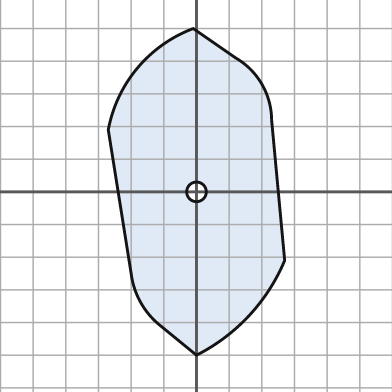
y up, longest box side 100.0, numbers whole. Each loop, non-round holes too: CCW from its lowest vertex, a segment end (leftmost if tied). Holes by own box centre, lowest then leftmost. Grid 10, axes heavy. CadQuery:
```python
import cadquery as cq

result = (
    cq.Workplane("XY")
    .moveTo(0.0, -50.0)
    .threePointArc((16.0, -38.0), (27.0, -21.0))
    .lineTo(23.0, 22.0)
    .threePointArc((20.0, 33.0), (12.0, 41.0))
    .lineTo(-1.0, 50.0)
    .threePointArc((-18.0, 38.0), (-27.0, 19.0))
    .lineTo(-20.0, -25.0)
    .threePointArc((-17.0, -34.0), (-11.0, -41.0))
    .close()
    .moveTo(0.0, 0.0)
    .circle(3.0)
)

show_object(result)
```